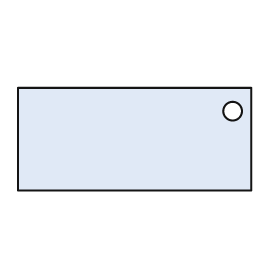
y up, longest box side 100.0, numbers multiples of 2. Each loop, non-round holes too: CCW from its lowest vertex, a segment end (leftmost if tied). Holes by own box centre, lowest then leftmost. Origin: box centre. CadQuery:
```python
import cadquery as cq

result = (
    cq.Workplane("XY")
    .moveTo(-50.0, -22.0)
    .lineTo(50.0, -22.0)
    .lineTo(50.0, 22.0)
    .lineTo(-50.0, 22.0)
    .close()
    .moveTo(42.0, 12.0)
    .circle(4.0)
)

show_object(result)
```